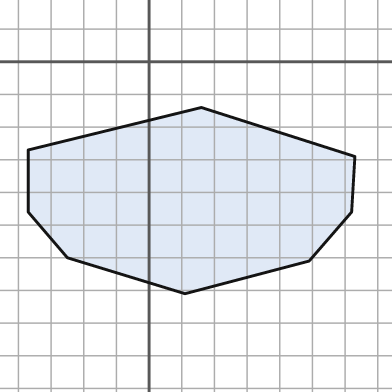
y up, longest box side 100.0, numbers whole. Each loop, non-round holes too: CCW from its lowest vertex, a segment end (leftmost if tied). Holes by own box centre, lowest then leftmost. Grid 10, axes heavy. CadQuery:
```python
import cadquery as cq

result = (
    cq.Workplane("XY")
    .moveTo(11.0, -71.0)
    .lineTo(49.0, -61.0)
    .lineTo(62.0, -46.0)
    .lineTo(63.0, -29.0)
    .lineTo(16.0, -14.0)
    .lineTo(-37.0, -27.0)
    .lineTo(-37.0, -46.0)
    .lineTo(-25.0, -60.0)
    .close()
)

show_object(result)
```